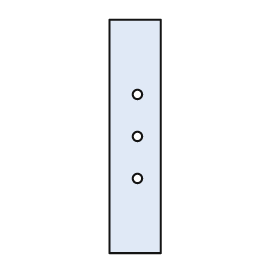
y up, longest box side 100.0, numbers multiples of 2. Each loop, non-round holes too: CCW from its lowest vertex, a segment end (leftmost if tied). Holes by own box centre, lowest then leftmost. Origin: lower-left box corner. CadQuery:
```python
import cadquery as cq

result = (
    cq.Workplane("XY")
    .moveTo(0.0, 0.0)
    .lineTo(22.0, 0.0)
    .lineTo(22.0, 100.0)
    .lineTo(0.0, 100.0)
    .close()
    .moveTo(12.0, 32.0)
    .circle(2.0)
    .moveTo(12.0, 50.0)
    .circle(2.0)
    .moveTo(12.0, 68.0)
    .circle(2.0)
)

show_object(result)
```